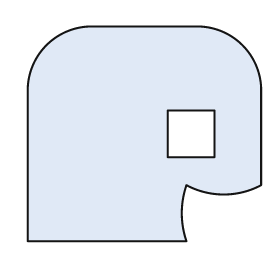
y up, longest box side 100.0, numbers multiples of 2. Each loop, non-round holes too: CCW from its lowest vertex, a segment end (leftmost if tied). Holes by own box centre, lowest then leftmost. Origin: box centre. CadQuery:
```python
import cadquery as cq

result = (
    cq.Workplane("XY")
    .moveTo(-50.0, -46.0)
    .lineTo(18.0, -46.0)
    .threePointArc((16.0, -34.0), (18.0, -22.0))
    .threePointArc((34.0, -26.0), (50.0, -22.0))
    .lineTo(50.0, 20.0)
    .threePointArc((42.0, 38.0), (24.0, 46.0))
    .lineTo(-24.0, 46.0)
    .threePointArc((-42.0, 38.0), (-50.0, 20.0))
    .close()
    .moveTo(10.0, -10.0)
    .lineTo(30.0, -10.0)
    .lineTo(30.0, 10.0)
    .lineTo(10.0, 10.0)
    .close()
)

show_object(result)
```